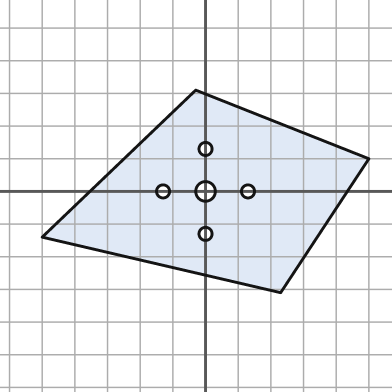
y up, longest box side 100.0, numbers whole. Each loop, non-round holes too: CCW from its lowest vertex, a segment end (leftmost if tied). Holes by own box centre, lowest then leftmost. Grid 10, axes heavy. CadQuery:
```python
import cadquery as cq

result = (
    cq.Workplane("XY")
    .moveTo(23.0, -31.0)
    .lineTo(50.0, 10.0)
    .lineTo(-3.0, 31.0)
    .lineTo(-50.0, -14.0)
    .close()
    .moveTo(0.0, -13.0)
    .circle(2.0)
    .moveTo(-13.0, 0.0)
    .circle(2.0)
    .moveTo(0.0, 0.0)
    .circle(3.0)
    .moveTo(13.0, 0.0)
    .circle(2.0)
    .moveTo(0.0, 13.0)
    .circle(2.0)
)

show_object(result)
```